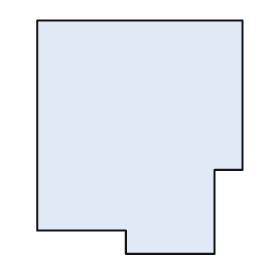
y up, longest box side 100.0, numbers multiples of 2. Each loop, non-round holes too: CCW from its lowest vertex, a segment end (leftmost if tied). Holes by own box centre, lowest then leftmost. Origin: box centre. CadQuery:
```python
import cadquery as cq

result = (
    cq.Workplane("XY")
    .moveTo(-6.0, -50.0)
    .lineTo(32.0, -50.0)
    .lineTo(32.0, -14.0)
    .lineTo(44.0, -14.0)
    .lineTo(44.0, 50.0)
    .lineTo(-44.0, 50.0)
    .lineTo(-44.0, -40.0)
    .lineTo(-6.0, -40.0)
    .close()
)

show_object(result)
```